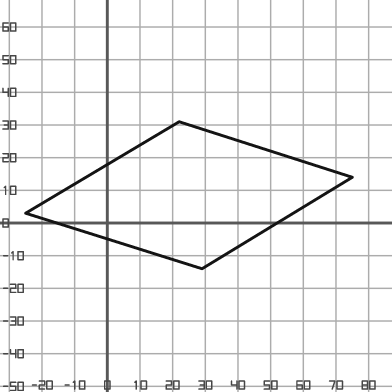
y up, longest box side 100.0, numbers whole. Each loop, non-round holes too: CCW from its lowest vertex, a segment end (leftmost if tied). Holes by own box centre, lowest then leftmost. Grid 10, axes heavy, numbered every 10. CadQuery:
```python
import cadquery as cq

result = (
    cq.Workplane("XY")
    .moveTo(29.0, -14.0)
    .lineTo(75.0, 14.0)
    .lineTo(22.0, 31.0)
    .lineTo(-25.0, 3.0)
    .close()
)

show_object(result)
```